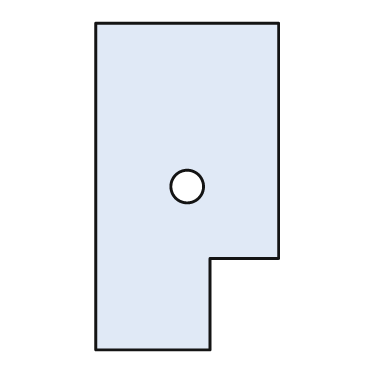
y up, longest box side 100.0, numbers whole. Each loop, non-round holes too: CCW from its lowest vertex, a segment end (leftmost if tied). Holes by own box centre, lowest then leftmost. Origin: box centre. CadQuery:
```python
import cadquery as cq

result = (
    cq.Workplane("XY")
    .moveTo(-28.0, -50.0)
    .lineTo(7.0, -50.0)
    .lineTo(7.0, -22.0)
    .lineTo(28.0, -22.0)
    .lineTo(28.0, 50.0)
    .lineTo(-28.0, 50.0)
    .close()
    .moveTo(0.0, 0.0)
    .circle(5.0)
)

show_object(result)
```